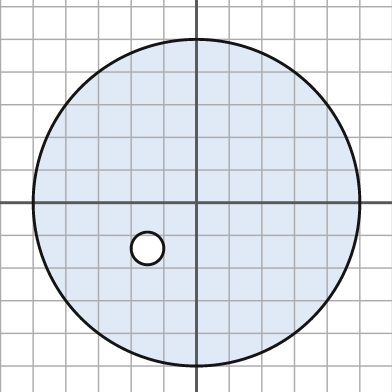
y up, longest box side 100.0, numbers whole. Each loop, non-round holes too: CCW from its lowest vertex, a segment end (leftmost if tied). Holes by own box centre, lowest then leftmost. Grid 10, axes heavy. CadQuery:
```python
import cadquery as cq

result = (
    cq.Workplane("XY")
    .moveTo(0.0, 0.0)
    .circle(50.0)
    .moveTo(-15.0, -14.0)
    .circle(5.0)
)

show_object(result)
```